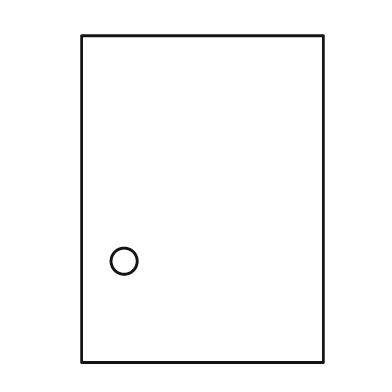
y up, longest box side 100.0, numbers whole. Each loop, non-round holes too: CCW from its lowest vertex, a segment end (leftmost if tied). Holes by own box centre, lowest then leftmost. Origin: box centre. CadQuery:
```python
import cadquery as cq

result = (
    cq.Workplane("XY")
    .moveTo(-37.0, -50.0)
    .lineTo(37.0, -50.0)
    .lineTo(37.0, 50.0)
    .lineTo(-37.0, 50.0)
    .close()
    .moveTo(-24.0, -19.0)
    .circle(4.0)
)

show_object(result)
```